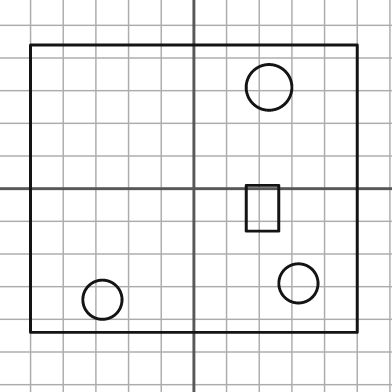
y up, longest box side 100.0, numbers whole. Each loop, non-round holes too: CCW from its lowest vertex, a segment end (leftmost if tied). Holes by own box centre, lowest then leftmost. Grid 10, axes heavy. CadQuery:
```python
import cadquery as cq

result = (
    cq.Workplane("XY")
    .moveTo(-50.0, -44.0)
    .lineTo(50.0, -44.0)
    .lineTo(50.0, 44.0)
    .lineTo(-50.0, 44.0)
    .close()
    .moveTo(-28.0, -34.0)
    .circle(6.0)
    .moveTo(32.0, -29.0)
    .circle(6.0)
    .moveTo(16.0, -13.0)
    .lineTo(26.0, -13.0)
    .lineTo(26.0, 1.0)
    .lineTo(16.0, 1.0)
    .close()
    .moveTo(23.0, 31.0)
    .circle(7.0)
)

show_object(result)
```